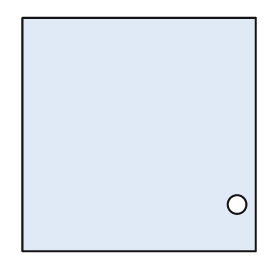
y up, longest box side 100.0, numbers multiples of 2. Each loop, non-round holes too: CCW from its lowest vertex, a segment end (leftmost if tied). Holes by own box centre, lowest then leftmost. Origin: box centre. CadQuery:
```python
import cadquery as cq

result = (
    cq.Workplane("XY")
    .moveTo(-50.0, -50.0)
    .lineTo(50.0, -50.0)
    .lineTo(50.0, 50.0)
    .lineTo(-50.0, 50.0)
    .close()
    .moveTo(42.0, -30.0)
    .circle(4.0)
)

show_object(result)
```